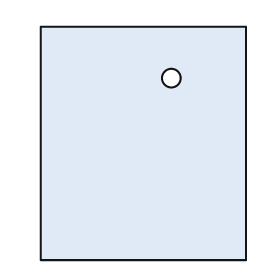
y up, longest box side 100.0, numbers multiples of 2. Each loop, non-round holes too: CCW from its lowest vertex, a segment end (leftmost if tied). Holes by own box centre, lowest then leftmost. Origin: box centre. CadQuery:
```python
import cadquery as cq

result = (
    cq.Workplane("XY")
    .moveTo(-44.0, -50.0)
    .lineTo(44.0, -50.0)
    .lineTo(44.0, 50.0)
    .lineTo(-44.0, 50.0)
    .close()
    .moveTo(12.0, 28.0)
    .circle(4.0)
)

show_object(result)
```